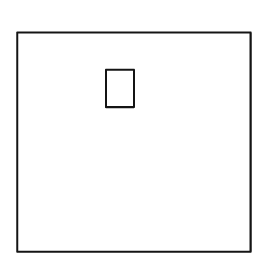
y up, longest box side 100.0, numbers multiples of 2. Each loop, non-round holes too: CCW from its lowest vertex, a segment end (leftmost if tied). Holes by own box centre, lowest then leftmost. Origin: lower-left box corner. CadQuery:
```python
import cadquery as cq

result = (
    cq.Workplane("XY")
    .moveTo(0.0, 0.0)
    .lineTo(100.0, 0.0)
    .lineTo(100.0, 94.0)
    .lineTo(0.0, 94.0)
    .close()
    .moveTo(38.0, 62.0)
    .lineTo(50.0, 62.0)
    .lineTo(50.0, 78.0)
    .lineTo(38.0, 78.0)
    .close()
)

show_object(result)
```